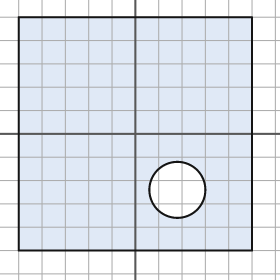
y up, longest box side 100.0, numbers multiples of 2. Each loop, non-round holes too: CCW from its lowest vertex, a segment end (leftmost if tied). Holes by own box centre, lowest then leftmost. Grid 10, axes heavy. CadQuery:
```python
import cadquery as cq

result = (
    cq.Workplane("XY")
    .moveTo(-50.0, -50.0)
    .lineTo(50.0, -50.0)
    .lineTo(50.0, 50.0)
    .lineTo(-50.0, 50.0)
    .close()
    .moveTo(18.0, -24.0)
    .circle(12.0)
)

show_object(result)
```